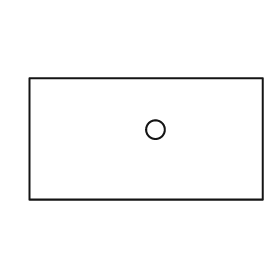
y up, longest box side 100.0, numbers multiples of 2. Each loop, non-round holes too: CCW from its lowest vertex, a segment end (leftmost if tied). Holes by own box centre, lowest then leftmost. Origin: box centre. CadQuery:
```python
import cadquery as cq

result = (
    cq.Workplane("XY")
    .moveTo(-50.0, -26.0)
    .lineTo(50.0, -26.0)
    .lineTo(50.0, 26.0)
    .lineTo(-50.0, 26.0)
    .close()
    .moveTo(4.0, 4.0)
    .circle(4.0)
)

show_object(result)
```